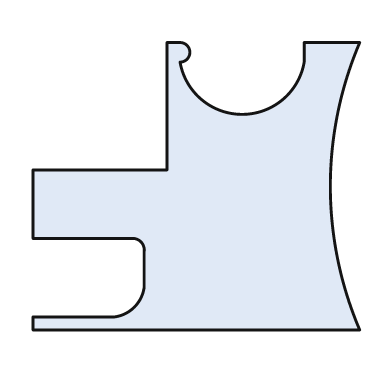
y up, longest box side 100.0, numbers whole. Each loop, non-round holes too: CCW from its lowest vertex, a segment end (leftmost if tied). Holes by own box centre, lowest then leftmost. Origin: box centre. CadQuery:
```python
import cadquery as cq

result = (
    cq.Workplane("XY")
    .moveTo(-50.0, -44.0)
    .lineTo(50.0, -44.0)
    .threePointArc((41.0, 0.0), (50.0, 44.0))
    .lineTo(33.0, 44.0)
    .lineTo(33.0, 38.0)
    .threePointArc((14.0, 22.0), (-5.0, 38.0))
    .threePointArc((-2.0, 41.0), (-5.0, 44.0))
    .lineTo(-9.0, 44.0)
    .lineTo(-9.0, 5.0)
    .lineTo(-50.0, 5.0)
    .lineTo(-50.0, -16.0)
    .lineTo(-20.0, -16.0)
    .threePointArc((-17.0, -17.0), (-16.0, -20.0))
    .lineTo(-16.0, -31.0)
    .threePointArc((-19.0, -37.0), (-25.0, -40.0))
    .lineTo(-50.0, -40.0)
    .close()
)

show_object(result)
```